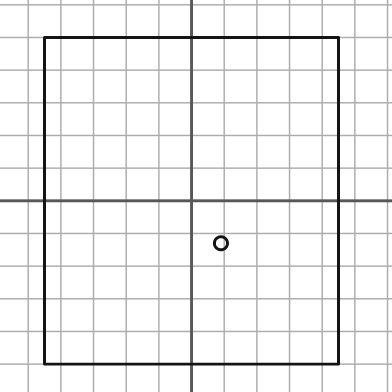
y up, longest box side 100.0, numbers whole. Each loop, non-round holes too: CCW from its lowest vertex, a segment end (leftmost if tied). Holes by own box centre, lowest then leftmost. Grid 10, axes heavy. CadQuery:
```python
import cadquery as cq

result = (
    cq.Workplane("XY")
    .moveTo(-45.0, -50.0)
    .lineTo(45.0, -50.0)
    .lineTo(45.0, 50.0)
    .lineTo(-45.0, 50.0)
    .close()
    .moveTo(9.0, -13.0)
    .circle(2.0)
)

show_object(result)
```